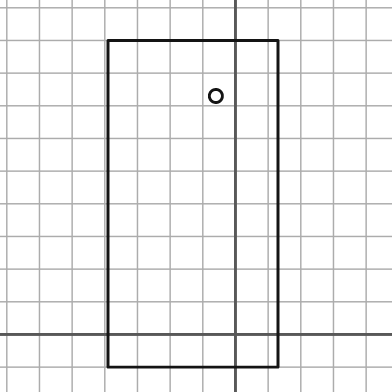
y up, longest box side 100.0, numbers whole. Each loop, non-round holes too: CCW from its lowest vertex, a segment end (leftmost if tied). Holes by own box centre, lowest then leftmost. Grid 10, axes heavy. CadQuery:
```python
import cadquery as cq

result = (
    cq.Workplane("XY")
    .moveTo(-39.0, -10.0)
    .lineTo(13.0, -10.0)
    .lineTo(13.0, 90.0)
    .lineTo(-39.0, 90.0)
    .close()
    .moveTo(-6.0, 73.0)
    .circle(2.0)
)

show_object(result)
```